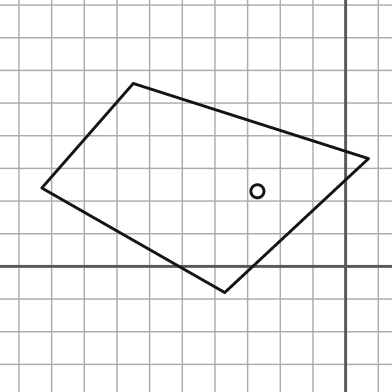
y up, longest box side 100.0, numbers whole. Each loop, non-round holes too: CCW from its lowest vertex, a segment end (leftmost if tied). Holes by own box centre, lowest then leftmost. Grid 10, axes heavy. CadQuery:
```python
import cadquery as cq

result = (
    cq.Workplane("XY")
    .moveTo(-37.0, -8.0)
    .lineTo(7.0, 33.0)
    .lineTo(-65.0, 56.0)
    .lineTo(-93.0, 24.0)
    .close()
    .moveTo(-27.0, 23.0)
    .circle(2.0)
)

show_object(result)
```